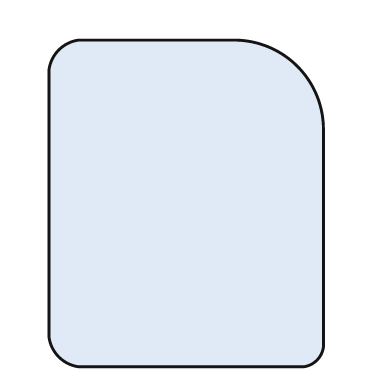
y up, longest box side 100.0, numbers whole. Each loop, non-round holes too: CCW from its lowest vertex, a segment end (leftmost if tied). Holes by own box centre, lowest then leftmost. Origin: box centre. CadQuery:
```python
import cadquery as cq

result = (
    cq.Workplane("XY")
    .moveTo(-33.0, -50.0)
    .lineTo(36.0, -50.0)
    .threePointArc((40.0, -48.0), (42.0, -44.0))
    .lineTo(42.0, 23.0)
    .threePointArc((34.0, 42.0), (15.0, 50.0))
    .lineTo(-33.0, 50.0)
    .threePointArc((-39.0, 47.0), (-42.0, 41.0))
    .lineTo(-42.0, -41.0)
    .threePointArc((-39.0, -47.0), (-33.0, -50.0))
    .close()
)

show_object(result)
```